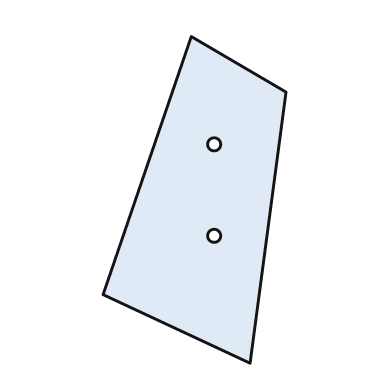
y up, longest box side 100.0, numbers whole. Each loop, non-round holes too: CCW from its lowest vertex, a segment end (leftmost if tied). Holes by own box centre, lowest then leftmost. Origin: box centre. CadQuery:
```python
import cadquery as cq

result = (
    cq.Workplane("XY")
    .moveTo(17.0, -50.0)
    .lineTo(28.0, 33.0)
    .lineTo(-1.0, 50.0)
    .lineTo(-28.0, -29.0)
    .close()
    .moveTo(6.0, -11.0)
    .circle(2.0)
    .moveTo(6.0, 17.0)
    .circle(2.0)
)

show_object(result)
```